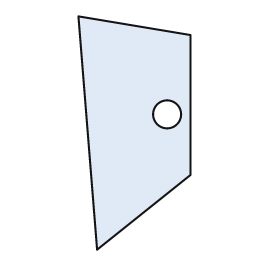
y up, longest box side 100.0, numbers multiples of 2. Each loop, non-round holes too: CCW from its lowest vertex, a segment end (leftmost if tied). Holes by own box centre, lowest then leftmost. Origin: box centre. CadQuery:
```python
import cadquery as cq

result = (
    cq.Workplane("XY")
    .moveTo(-16.0, -50.0)
    .lineTo(24.0, -18.0)
    .lineTo(24.0, 42.0)
    .lineTo(-24.0, 50.0)
    .close()
    .moveTo(14.0, 8.0)
    .circle(6.0)
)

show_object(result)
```